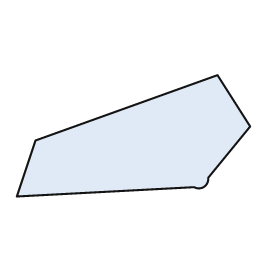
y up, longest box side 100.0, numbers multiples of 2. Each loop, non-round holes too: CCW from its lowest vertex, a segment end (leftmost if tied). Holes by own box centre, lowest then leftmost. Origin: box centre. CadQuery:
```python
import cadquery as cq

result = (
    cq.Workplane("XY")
    .moveTo(-50.0, -26.0)
    .lineTo(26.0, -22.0)
    .threePointArc((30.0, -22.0), (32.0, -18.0))
    .lineTo(50.0, 4.0)
    .lineTo(36.0, 26.0)
    .lineTo(-42.0, -2.0)
    .close()
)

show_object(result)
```